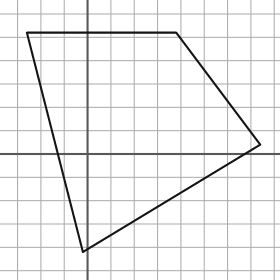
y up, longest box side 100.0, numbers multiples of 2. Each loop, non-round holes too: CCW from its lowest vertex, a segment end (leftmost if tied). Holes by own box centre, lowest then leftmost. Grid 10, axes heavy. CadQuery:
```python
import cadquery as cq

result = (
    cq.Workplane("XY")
    .moveTo(-2.0, -42.0)
    .lineTo(74.0, 4.0)
    .lineTo(38.0, 52.0)
    .lineTo(-26.0, 52.0)
    .close()
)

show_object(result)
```